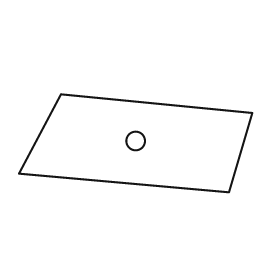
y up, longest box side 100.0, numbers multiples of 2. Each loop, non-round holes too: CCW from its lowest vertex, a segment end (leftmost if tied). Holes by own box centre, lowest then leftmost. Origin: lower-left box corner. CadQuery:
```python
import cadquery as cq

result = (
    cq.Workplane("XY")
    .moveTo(90.0, 0.0)
    .lineTo(100.0, 34.0)
    .lineTo(18.0, 42.0)
    .lineTo(0.0, 8.0)
    .close()
    .moveTo(50.0, 22.0)
    .circle(4.0)
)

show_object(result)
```